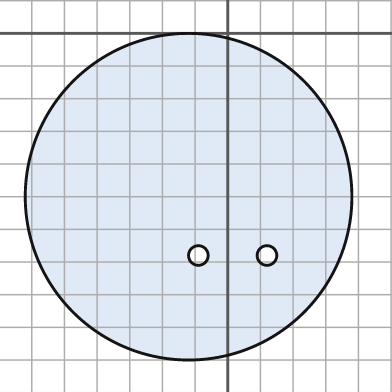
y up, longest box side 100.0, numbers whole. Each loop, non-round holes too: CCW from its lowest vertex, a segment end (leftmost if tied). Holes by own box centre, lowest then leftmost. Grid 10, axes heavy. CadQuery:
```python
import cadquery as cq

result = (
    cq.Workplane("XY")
    .moveTo(-12.0, -50.0)
    .circle(50.0)
    .moveTo(-9.0, -68.0)
    .circle(3.0)
    .moveTo(12.0, -68.0)
    .circle(3.0)
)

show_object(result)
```